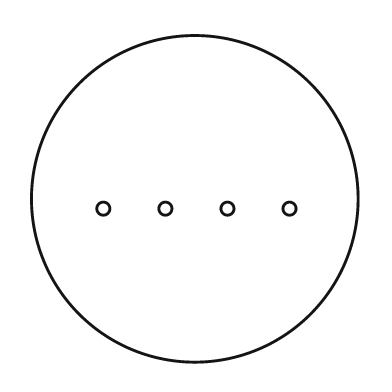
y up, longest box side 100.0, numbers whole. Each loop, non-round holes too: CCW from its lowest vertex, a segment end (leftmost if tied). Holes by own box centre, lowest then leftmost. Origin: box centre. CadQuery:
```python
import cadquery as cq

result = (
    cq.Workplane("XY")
    .moveTo(0.0, 0.0)
    .circle(50.0)
    .moveTo(-28.0, -3.0)
    .circle(2.0)
    .moveTo(-9.0, -3.0)
    .circle(2.0)
    .moveTo(10.0, -3.0)
    .circle(2.0)
    .moveTo(29.0, -3.0)
    .circle(2.0)
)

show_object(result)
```